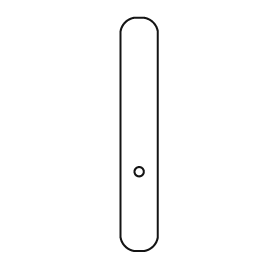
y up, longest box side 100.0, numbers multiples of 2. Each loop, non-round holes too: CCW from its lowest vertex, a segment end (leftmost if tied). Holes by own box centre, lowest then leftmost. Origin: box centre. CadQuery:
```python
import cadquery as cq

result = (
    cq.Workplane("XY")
    .moveTo(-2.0, -50.0)
    .lineTo(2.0, -50.0)
    .threePointArc((6.0, -48.0), (8.0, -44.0))
    .lineTo(8.0, 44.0)
    .threePointArc((6.0, 48.0), (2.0, 50.0))
    .lineTo(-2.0, 50.0)
    .threePointArc((-6.0, 48.0), (-8.0, 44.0))
    .lineTo(-8.0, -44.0)
    .threePointArc((-6.0, -48.0), (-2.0, -50.0))
    .close()
    .moveTo(0.0, -16.0)
    .circle(2.0)
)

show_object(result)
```